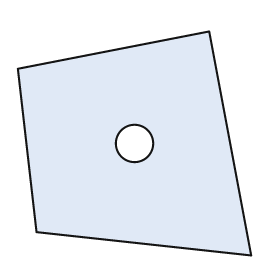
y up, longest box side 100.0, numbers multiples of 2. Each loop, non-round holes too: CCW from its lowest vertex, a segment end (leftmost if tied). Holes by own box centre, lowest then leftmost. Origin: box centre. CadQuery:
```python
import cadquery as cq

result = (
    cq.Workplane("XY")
    .moveTo(50.0, -48.0)
    .lineTo(32.0, 48.0)
    .lineTo(-50.0, 32.0)
    .lineTo(-42.0, -38.0)
    .close()
    .moveTo(0.0, 0.0)
    .circle(8.0)
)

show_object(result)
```